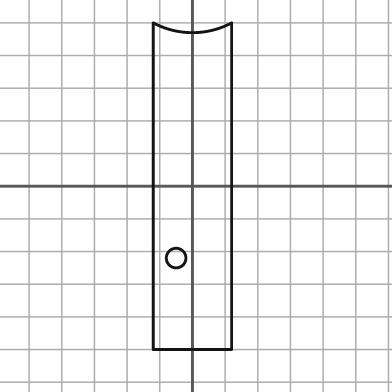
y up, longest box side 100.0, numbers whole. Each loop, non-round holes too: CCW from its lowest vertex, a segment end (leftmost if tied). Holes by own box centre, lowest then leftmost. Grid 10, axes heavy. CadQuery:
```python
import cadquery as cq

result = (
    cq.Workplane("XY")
    .moveTo(-12.0, -50.0)
    .lineTo(12.0, -50.0)
    .lineTo(12.0, 50.0)
    .threePointArc((0.0, 47.0), (-12.0, 50.0))
    .close()
    .moveTo(-5.0, -22.0)
    .circle(3.0)
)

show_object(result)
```